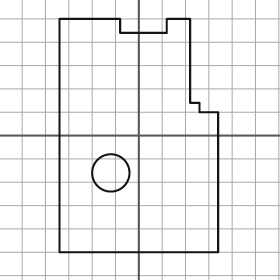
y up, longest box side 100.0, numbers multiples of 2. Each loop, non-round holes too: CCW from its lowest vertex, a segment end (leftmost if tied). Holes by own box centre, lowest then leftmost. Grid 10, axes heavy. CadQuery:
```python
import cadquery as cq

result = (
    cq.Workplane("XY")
    .moveTo(-34.0, -50.0)
    .lineTo(34.0, -50.0)
    .lineTo(34.0, 10.0)
    .lineTo(26.0, 10.0)
    .lineTo(26.0, 14.0)
    .lineTo(22.0, 14.0)
    .lineTo(22.0, 50.0)
    .lineTo(12.0, 50.0)
    .lineTo(12.0, 44.0)
    .lineTo(-8.0, 44.0)
    .lineTo(-8.0, 50.0)
    .lineTo(-34.0, 50.0)
    .close()
    .moveTo(-12.0, -16.0)
    .circle(8.0)
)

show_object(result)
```